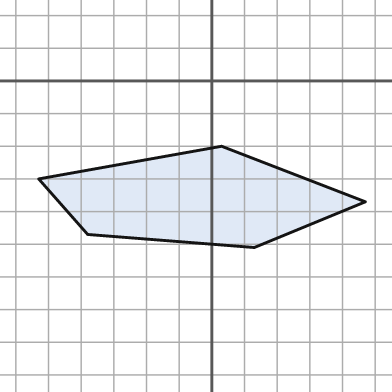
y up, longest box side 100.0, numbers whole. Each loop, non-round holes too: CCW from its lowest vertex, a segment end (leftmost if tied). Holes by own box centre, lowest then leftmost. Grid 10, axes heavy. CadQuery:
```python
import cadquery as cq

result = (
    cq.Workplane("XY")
    .moveTo(13.0, -51.0)
    .lineTo(47.0, -37.0)
    .lineTo(3.0, -20.0)
    .lineTo(-53.0, -30.0)
    .lineTo(-38.0, -47.0)
    .close()
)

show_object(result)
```